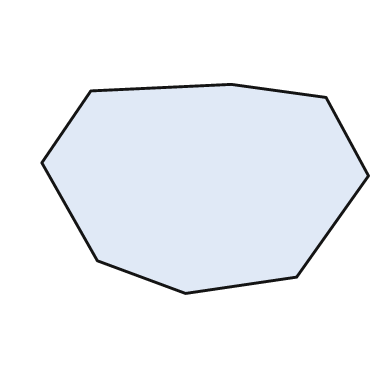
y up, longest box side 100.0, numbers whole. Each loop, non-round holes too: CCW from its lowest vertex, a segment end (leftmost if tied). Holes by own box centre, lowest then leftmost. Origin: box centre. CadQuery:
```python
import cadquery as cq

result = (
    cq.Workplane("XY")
    .moveTo(-6.0, -32.0)
    .lineTo(28.0, -27.0)
    .lineTo(50.0, 4.0)
    .lineTo(37.0, 28.0)
    .lineTo(8.0, 32.0)
    .lineTo(-35.0, 30.0)
    .lineTo(-50.0, 8.0)
    .lineTo(-33.0, -22.0)
    .close()
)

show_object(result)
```